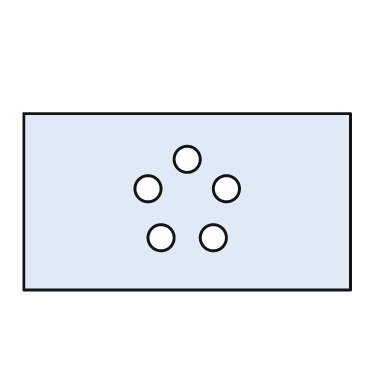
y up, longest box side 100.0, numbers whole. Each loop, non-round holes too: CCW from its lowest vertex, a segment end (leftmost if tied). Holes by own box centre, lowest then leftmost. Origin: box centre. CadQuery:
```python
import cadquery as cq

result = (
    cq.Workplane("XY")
    .moveTo(-50.0, -27.0)
    .lineTo(50.0, -27.0)
    .lineTo(50.0, 27.0)
    .lineTo(-50.0, 27.0)
    .close()
    .moveTo(-8.0, -11.0)
    .circle(4.0)
    .moveTo(8.0, -11.0)
    .circle(4.0)
    .moveTo(-12.0, 4.0)
    .circle(4.0)
    .moveTo(12.0, 4.0)
    .circle(4.0)
    .moveTo(0.0, 13.0)
    .circle(4.0)
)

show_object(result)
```